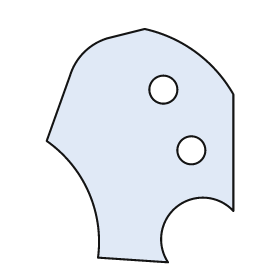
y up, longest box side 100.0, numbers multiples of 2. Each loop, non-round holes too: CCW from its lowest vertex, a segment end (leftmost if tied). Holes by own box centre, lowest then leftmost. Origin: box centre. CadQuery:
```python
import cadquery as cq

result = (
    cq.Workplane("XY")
    .moveTo(12.0, -50.0)
    .threePointArc((16.0, -26.0), (40.0, -28.0))
    .lineTo(40.0, 22.0)
    .threePointArc((24.0, 40.0), (2.0, 50.0))
    .lineTo(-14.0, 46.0)
    .threePointArc((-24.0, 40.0), (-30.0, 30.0))
    .lineTo(-40.0, 2.0)
    .threePointArc((-22.0, -20.0), (-18.0, -48.0))
    .close()
    .moveTo(22.0, -2.0)
    .circle(6.0)
    .moveTo(10.0, 24.0)
    .circle(6.0)
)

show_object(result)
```